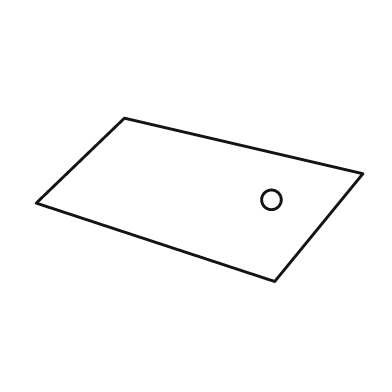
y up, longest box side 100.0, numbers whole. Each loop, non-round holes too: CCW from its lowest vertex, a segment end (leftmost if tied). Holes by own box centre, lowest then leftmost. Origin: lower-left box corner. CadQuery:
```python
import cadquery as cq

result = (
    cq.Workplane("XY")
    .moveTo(73.0, 0.0)
    .lineTo(100.0, 33.0)
    .lineTo(27.0, 50.0)
    .lineTo(0.0, 24.0)
    .close()
    .moveTo(72.0, 25.0)
    .circle(3.0)
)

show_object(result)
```